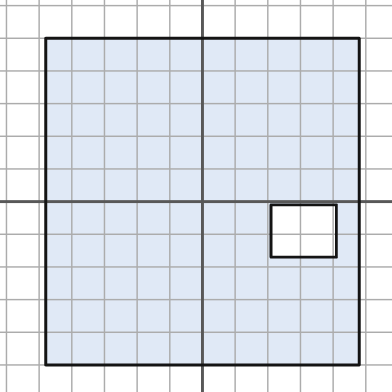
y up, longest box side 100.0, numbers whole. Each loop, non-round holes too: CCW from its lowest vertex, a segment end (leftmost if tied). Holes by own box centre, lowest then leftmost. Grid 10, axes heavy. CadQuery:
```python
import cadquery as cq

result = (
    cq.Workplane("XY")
    .moveTo(-48.0, -50.0)
    .lineTo(48.0, -50.0)
    .lineTo(48.0, 50.0)
    .lineTo(-48.0, 50.0)
    .close()
    .moveTo(21.0, -17.0)
    .lineTo(41.0, -17.0)
    .lineTo(41.0, -1.0)
    .lineTo(21.0, -1.0)
    .close()
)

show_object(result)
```